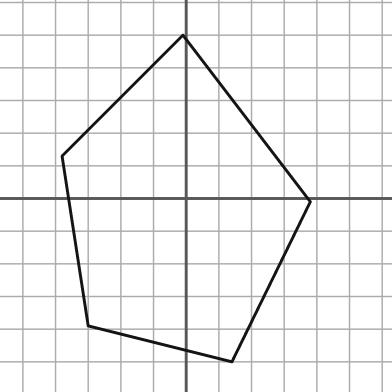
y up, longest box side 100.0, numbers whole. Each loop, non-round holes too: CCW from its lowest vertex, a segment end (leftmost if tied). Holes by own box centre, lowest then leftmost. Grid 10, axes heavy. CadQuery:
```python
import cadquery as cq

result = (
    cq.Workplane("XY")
    .moveTo(14.0, -50.0)
    .lineTo(38.0, -1.0)
    .lineTo(-1.0, 50.0)
    .lineTo(-38.0, 13.0)
    .lineTo(-30.0, -39.0)
    .close()
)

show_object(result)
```